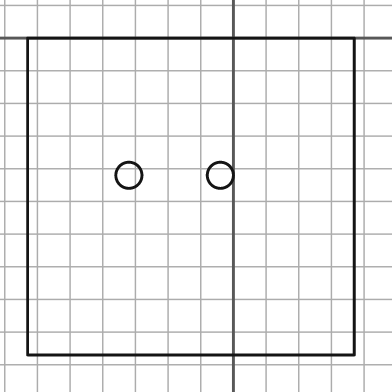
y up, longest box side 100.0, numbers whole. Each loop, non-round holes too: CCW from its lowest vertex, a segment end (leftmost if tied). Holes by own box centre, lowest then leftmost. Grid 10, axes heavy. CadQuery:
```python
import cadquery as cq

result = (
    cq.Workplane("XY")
    .moveTo(-63.0, -97.0)
    .lineTo(37.0, -97.0)
    .lineTo(37.0, 0.0)
    .lineTo(-63.0, 0.0)
    .close()
    .moveTo(-32.0, -42.0)
    .circle(4.0)
    .moveTo(-4.0, -42.0)
    .circle(4.0)
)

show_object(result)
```